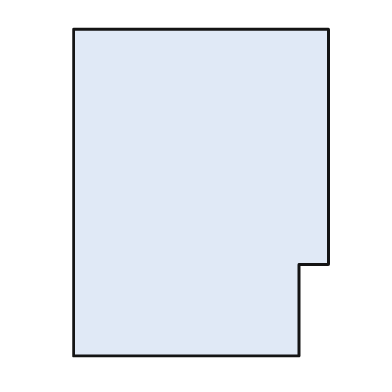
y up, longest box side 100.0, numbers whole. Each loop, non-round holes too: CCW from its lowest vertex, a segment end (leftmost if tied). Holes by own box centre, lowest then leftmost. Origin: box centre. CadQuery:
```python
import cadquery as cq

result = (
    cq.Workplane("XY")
    .moveTo(-39.0, -50.0)
    .lineTo(30.0, -50.0)
    .lineTo(30.0, -22.0)
    .lineTo(39.0, -22.0)
    .lineTo(39.0, 50.0)
    .lineTo(-39.0, 50.0)
    .close()
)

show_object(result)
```